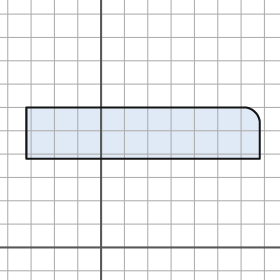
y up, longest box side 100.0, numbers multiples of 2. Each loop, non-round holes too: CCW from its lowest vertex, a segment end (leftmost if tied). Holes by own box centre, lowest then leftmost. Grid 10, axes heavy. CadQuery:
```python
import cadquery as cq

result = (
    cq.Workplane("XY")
    .moveTo(-32.0, 38.0)
    .lineTo(68.0, 38.0)
    .lineTo(68.0, 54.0)
    .threePointArc((66.0, 58.0), (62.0, 60.0))
    .lineTo(-32.0, 60.0)
    .close()
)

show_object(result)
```